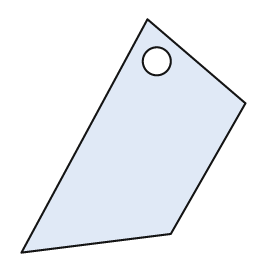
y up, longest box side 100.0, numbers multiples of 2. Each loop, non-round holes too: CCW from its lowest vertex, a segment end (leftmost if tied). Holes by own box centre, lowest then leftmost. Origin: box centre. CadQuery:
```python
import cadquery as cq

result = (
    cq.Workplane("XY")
    .moveTo(-48.0, -50.0)
    .lineTo(16.0, -42.0)
    .lineTo(48.0, 14.0)
    .lineTo(6.0, 50.0)
    .close()
    .moveTo(10.0, 32.0)
    .circle(6.0)
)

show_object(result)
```